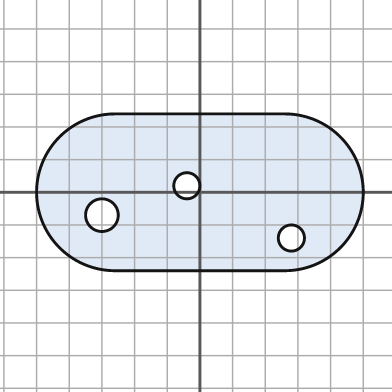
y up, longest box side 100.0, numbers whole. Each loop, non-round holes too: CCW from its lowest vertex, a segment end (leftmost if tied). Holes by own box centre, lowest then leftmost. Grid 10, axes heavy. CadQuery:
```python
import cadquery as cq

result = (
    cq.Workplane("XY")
    .moveTo(-26.0, -24.0)
    .lineTo(26.0, -24.0)
    .threePointArc((50.0, 0.0), (26.0, 24.0))
    .lineTo(-26.0, 24.0)
    .threePointArc((-50.0, 0.0), (-26.0, -24.0))
    .close()
    .moveTo(28.0, -14.0)
    .circle(4.0)
    .moveTo(-30.0, -7.0)
    .circle(5.0)
    .moveTo(-4.0, 2.0)
    .circle(4.0)
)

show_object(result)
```